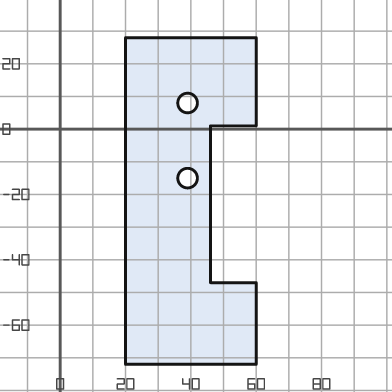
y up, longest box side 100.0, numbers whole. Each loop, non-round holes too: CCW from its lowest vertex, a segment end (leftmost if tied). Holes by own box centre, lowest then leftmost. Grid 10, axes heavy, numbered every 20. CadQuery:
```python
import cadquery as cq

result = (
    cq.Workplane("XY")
    .moveTo(20.0, -72.0)
    .lineTo(60.0, -72.0)
    .lineTo(60.0, -47.0)
    .lineTo(46.0, -47.0)
    .lineTo(46.0, 1.0)
    .lineTo(60.0, 1.0)
    .lineTo(60.0, 28.0)
    .lineTo(20.0, 28.0)
    .close()
    .moveTo(39.0, -15.0)
    .circle(3.0)
    .moveTo(39.0, 8.0)
    .circle(3.0)
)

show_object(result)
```